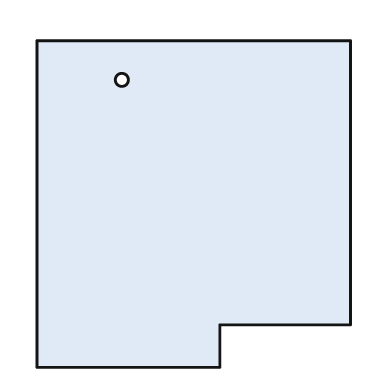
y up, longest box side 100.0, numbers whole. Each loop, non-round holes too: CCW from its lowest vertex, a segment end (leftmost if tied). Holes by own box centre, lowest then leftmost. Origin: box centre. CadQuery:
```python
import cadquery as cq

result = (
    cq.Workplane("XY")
    .moveTo(-48.0, -50.0)
    .lineTo(8.0, -50.0)
    .lineTo(8.0, -37.0)
    .lineTo(48.0, -37.0)
    .lineTo(48.0, 50.0)
    .lineTo(-48.0, 50.0)
    .close()
    .moveTo(-22.0, 38.0)
    .circle(2.0)
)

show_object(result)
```